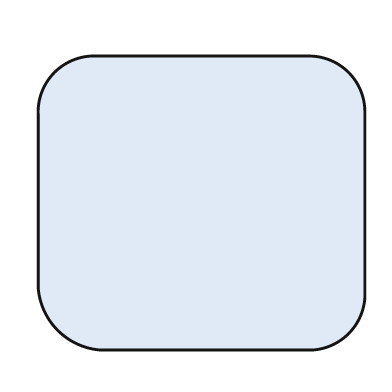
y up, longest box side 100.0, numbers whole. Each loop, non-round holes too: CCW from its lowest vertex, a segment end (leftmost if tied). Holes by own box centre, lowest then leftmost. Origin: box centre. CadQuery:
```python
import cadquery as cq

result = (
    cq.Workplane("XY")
    .moveTo(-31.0, -45.0)
    .lineTo(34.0, -45.0)
    .threePointArc((45.0, -40.0), (50.0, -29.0))
    .lineTo(50.0, 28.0)
    .threePointArc((45.0, 40.0), (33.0, 45.0))
    .lineTo(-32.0, 45.0)
    .threePointArc((-45.0, 40.0), (-50.0, 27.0))
    .lineTo(-50.0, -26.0)
    .threePointArc((-44.0, -39.0), (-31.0, -45.0))
    .close()
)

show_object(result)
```